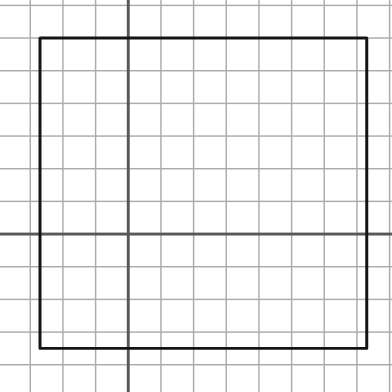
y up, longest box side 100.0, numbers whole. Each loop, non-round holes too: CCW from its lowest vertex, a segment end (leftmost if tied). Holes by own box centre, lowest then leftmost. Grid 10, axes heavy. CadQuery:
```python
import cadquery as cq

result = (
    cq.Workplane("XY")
    .moveTo(-27.0, -35.0)
    .lineTo(73.0, -35.0)
    .lineTo(73.0, 60.0)
    .lineTo(-27.0, 60.0)
    .close()
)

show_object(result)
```